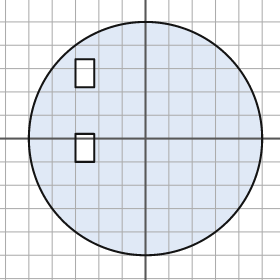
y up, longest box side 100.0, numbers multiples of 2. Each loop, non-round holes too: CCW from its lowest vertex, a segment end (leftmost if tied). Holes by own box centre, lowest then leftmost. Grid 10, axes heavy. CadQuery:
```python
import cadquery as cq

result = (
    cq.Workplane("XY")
    .moveTo(0.0, 0.0)
    .circle(50.0)
    .moveTo(-30.0, -10.0)
    .lineTo(-22.0, -10.0)
    .lineTo(-22.0, 2.0)
    .lineTo(-30.0, 2.0)
    .close()
    .moveTo(-30.0, 22.0)
    .lineTo(-22.0, 22.0)
    .lineTo(-22.0, 34.0)
    .lineTo(-30.0, 34.0)
    .close()
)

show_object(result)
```